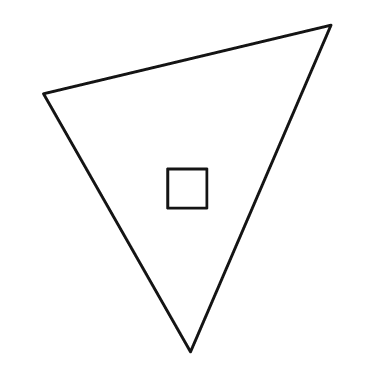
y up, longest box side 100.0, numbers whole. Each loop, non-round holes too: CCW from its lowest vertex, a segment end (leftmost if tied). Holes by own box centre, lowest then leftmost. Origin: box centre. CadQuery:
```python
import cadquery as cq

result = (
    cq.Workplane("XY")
    .moveTo(1.0, -50.0)
    .lineTo(44.0, 50.0)
    .lineTo(-44.0, 29.0)
    .close()
    .moveTo(-6.0, -6.0)
    .lineTo(6.0, -6.0)
    .lineTo(6.0, 6.0)
    .lineTo(-6.0, 6.0)
    .close()
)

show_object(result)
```